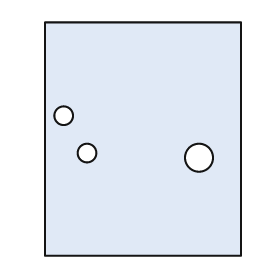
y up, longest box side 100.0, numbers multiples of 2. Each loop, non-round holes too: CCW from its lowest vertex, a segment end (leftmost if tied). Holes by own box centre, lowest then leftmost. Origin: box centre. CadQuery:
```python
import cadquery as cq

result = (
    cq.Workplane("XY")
    .moveTo(-42.0, -50.0)
    .lineTo(42.0, -50.0)
    .lineTo(42.0, 50.0)
    .lineTo(-42.0, 50.0)
    .close()
    .moveTo(24.0, -8.0)
    .circle(6.0)
    .moveTo(-24.0, -6.0)
    .circle(4.0)
    .moveTo(-34.0, 10.0)
    .circle(4.0)
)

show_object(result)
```